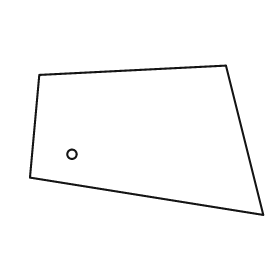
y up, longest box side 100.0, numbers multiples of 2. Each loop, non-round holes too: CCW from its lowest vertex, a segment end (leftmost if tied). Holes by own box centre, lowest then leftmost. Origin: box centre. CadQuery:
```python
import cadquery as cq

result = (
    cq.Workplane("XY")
    .moveTo(50.0, -32.0)
    .lineTo(34.0, 32.0)
    .lineTo(-46.0, 28.0)
    .lineTo(-50.0, -16.0)
    .close()
    .moveTo(-32.0, -6.0)
    .circle(2.0)
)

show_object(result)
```